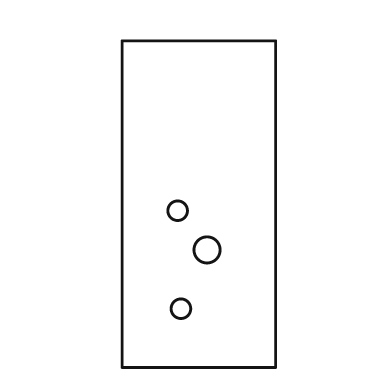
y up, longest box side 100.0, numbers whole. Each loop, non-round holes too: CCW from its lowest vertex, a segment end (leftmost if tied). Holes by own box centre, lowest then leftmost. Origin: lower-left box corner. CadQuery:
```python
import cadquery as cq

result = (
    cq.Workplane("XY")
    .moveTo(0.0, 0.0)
    .lineTo(47.0, 0.0)
    .lineTo(47.0, 100.0)
    .lineTo(0.0, 100.0)
    .close()
    .moveTo(18.0, 18.0)
    .circle(3.0)
    .moveTo(26.0, 36.0)
    .circle(4.0)
    .moveTo(17.0, 48.0)
    .circle(3.0)
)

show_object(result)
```